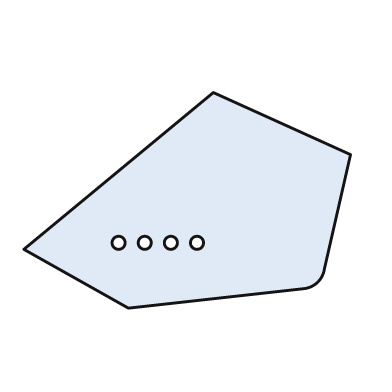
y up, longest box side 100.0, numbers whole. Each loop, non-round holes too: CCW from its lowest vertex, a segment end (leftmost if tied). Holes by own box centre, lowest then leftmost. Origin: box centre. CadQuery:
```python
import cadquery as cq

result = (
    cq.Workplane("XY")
    .moveTo(-18.0, -33.0)
    .lineTo(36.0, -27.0)
    .threePointArc((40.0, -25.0), (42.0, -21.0))
    .lineTo(50.0, 14.0)
    .lineTo(8.0, 33.0)
    .lineTo(-50.0, -15.0)
    .close()
    .moveTo(-21.0, -13.0)
    .circle(2.0)
    .moveTo(-13.0, -13.0)
    .circle(2.0)
    .moveTo(-5.0, -13.0)
    .circle(2.0)
    .moveTo(3.0, -13.0)
    .circle(2.0)
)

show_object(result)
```